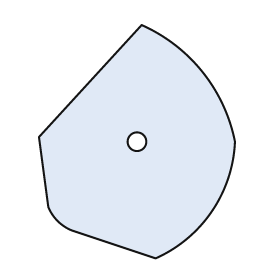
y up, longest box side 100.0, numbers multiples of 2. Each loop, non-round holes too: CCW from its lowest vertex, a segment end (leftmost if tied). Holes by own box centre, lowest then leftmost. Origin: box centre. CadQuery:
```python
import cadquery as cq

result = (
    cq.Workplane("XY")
    .moveTo(8.0, -50.0)
    .threePointArc((32.0, -30.0), (42.0, 0.0))
    .threePointArc((28.0, 30.0), (2.0, 50.0))
    .lineTo(-42.0, 2.0)
    .lineTo(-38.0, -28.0)
    .threePointArc((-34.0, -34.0), (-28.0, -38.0))
    .close()
    .moveTo(0.0, 0.0)
    .circle(4.0)
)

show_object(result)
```